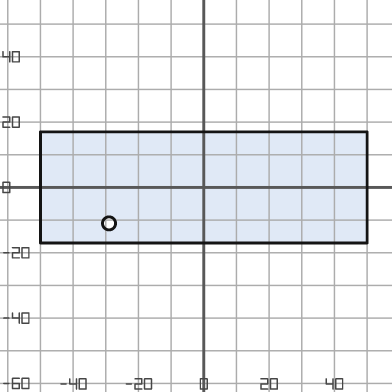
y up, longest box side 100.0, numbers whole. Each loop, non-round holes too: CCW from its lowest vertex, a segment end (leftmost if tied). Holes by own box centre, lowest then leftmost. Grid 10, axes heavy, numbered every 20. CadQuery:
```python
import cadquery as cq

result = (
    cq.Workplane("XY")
    .moveTo(-50.0, -17.0)
    .lineTo(50.0, -17.0)
    .lineTo(50.0, 17.0)
    .lineTo(-50.0, 17.0)
    .close()
    .moveTo(-29.0, -11.0)
    .circle(2.0)
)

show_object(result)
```